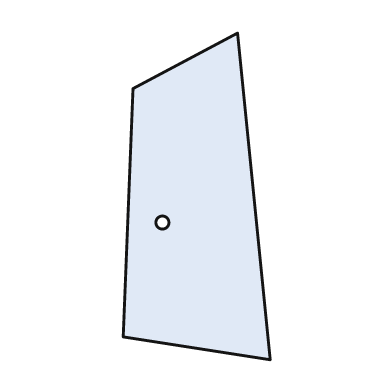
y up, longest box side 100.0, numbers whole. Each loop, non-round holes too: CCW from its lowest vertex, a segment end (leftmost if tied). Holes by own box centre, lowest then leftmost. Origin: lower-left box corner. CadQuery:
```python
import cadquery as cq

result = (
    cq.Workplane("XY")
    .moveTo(45.0, 0.0)
    .lineTo(35.0, 100.0)
    .lineTo(3.0, 83.0)
    .lineTo(0.0, 7.0)
    .close()
    .moveTo(12.0, 42.0)
    .circle(2.0)
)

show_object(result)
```